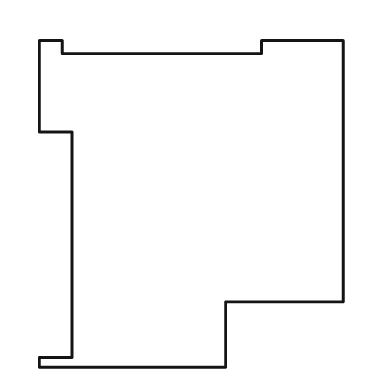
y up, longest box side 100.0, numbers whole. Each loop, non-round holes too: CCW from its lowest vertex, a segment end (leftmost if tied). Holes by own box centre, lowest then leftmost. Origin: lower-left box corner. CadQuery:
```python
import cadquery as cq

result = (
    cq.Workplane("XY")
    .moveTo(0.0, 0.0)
    .lineTo(57.0, 0.0)
    .lineTo(57.0, 20.0)
    .lineTo(93.0, 20.0)
    .lineTo(93.0, 100.0)
    .lineTo(68.0, 100.0)
    .lineTo(68.0, 96.0)
    .lineTo(7.0, 96.0)
    .lineTo(7.0, 100.0)
    .lineTo(0.0, 100.0)
    .lineTo(0.0, 72.0)
    .lineTo(10.0, 72.0)
    .lineTo(10.0, 3.0)
    .lineTo(0.0, 3.0)
    .close()
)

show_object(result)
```